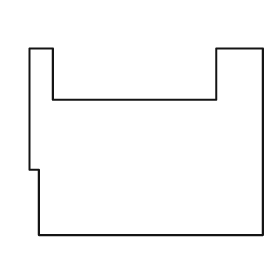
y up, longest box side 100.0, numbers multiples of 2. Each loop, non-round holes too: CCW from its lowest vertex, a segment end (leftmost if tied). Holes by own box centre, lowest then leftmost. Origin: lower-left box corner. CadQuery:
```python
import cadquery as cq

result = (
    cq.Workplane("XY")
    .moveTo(4.0, 0.0)
    .lineTo(100.0, 0.0)
    .lineTo(100.0, 80.0)
    .lineTo(80.0, 80.0)
    .lineTo(80.0, 58.0)
    .lineTo(10.0, 58.0)
    .lineTo(10.0, 80.0)
    .lineTo(0.0, 80.0)
    .lineTo(0.0, 28.0)
    .lineTo(4.0, 28.0)
    .close()
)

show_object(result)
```